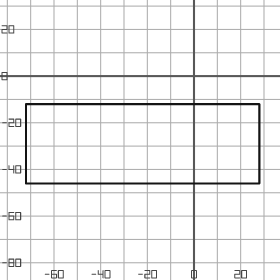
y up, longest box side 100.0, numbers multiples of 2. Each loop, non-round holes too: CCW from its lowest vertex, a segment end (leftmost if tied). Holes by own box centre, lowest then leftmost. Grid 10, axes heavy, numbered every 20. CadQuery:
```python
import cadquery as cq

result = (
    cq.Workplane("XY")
    .moveTo(-72.0, -46.0)
    .lineTo(28.0, -46.0)
    .lineTo(28.0, -12.0)
    .lineTo(-72.0, -12.0)
    .close()
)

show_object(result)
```